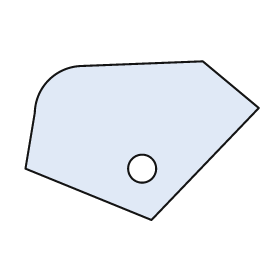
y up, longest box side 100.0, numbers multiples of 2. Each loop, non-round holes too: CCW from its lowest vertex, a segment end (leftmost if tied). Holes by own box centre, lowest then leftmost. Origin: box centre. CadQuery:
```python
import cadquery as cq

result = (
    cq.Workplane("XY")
    .moveTo(4.0, -34.0)
    .lineTo(50.0, 14.0)
    .lineTo(26.0, 34.0)
    .lineTo(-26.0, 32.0)
    .threePointArc((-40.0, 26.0), (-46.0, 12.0))
    .lineTo(-50.0, -12.0)
    .close()
    .moveTo(0.0, -12.0)
    .circle(6.0)
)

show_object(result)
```